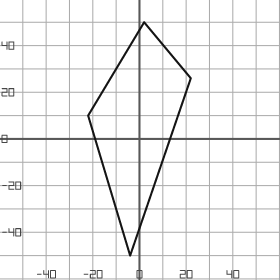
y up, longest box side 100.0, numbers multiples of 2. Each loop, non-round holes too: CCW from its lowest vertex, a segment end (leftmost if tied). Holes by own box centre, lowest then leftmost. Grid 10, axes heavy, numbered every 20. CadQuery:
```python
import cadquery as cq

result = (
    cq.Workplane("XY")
    .moveTo(-4.0, -50.0)
    .lineTo(22.0, 26.0)
    .lineTo(2.0, 50.0)
    .lineTo(-22.0, 10.0)
    .close()
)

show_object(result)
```